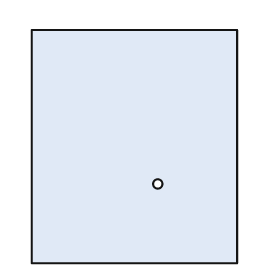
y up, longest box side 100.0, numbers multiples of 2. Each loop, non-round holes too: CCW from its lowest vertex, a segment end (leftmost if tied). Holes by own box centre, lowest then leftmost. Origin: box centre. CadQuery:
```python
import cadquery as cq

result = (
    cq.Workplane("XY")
    .moveTo(-44.0, -50.0)
    .lineTo(44.0, -50.0)
    .lineTo(44.0, 50.0)
    .lineTo(-44.0, 50.0)
    .close()
    .moveTo(10.0, -16.0)
    .circle(2.0)
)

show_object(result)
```